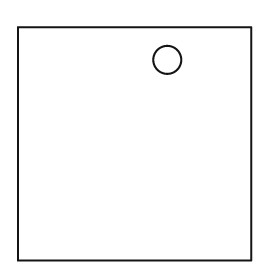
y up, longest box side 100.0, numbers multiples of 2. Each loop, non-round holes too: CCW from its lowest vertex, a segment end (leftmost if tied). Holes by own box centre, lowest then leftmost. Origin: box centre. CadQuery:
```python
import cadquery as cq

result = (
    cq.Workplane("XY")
    .moveTo(-50.0, -50.0)
    .lineTo(50.0, -50.0)
    .lineTo(50.0, 50.0)
    .lineTo(-50.0, 50.0)
    .close()
    .moveTo(14.0, 36.0)
    .circle(6.0)
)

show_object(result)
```